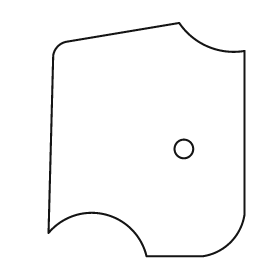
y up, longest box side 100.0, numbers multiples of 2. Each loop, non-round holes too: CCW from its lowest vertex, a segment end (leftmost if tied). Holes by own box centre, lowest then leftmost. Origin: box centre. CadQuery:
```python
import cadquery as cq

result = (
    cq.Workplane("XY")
    .moveTo(0.0, -50.0)
    .lineTo(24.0, -50.0)
    .threePointArc((36.0, -44.0), (42.0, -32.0))
    .lineTo(42.0, 38.0)
    .threePointArc((26.0, 40.0), (14.0, 50.0))
    .lineTo(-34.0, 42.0)
    .threePointArc((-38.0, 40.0), (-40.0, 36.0))
    .lineTo(-42.0, -40.0)
    .threePointArc((-18.0, -32.0), (0.0, -50.0))
    .close()
    .moveTo(16.0, -4.0)
    .circle(4.0)
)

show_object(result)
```